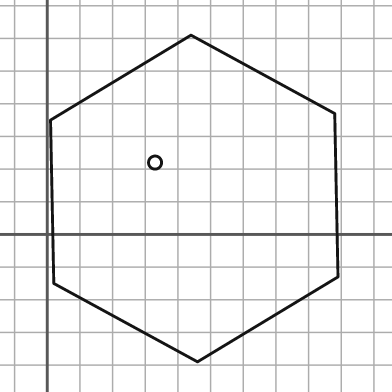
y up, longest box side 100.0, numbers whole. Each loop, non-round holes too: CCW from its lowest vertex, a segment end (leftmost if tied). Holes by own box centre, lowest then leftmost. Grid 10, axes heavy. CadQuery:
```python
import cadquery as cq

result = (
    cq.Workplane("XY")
    .moveTo(46.0, -39.0)
    .lineTo(89.0, -13.0)
    .lineTo(88.0, 37.0)
    .lineTo(44.0, 61.0)
    .lineTo(1.0, 35.0)
    .lineTo(2.0, -15.0)
    .close()
    .moveTo(33.0, 22.0)
    .circle(2.0)
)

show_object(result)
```